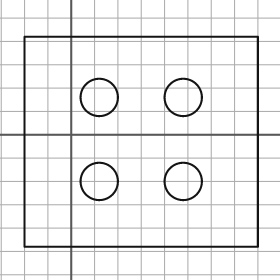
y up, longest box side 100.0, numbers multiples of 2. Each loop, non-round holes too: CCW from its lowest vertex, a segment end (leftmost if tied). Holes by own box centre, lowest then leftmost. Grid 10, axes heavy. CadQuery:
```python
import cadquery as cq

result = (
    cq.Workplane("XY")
    .moveTo(-20.0, -48.0)
    .lineTo(80.0, -48.0)
    .lineTo(80.0, 42.0)
    .lineTo(-20.0, 42.0)
    .close()
    .moveTo(12.0, -20.0)
    .circle(8.0)
    .moveTo(48.0, -20.0)
    .circle(8.0)
    .moveTo(12.0, 16.0)
    .circle(8.0)
    .moveTo(48.0, 16.0)
    .circle(8.0)
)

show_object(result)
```